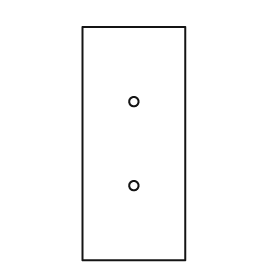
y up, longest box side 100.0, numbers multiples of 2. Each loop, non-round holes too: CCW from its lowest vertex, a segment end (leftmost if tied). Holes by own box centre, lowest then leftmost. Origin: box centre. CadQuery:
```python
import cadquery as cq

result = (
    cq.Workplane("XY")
    .moveTo(-22.0, -50.0)
    .lineTo(22.0, -50.0)
    .lineTo(22.0, 50.0)
    .lineTo(-22.0, 50.0)
    .close()
    .moveTo(0.0, -18.0)
    .circle(2.0)
    .moveTo(0.0, 18.0)
    .circle(2.0)
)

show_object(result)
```